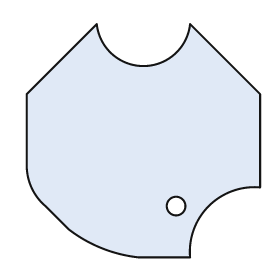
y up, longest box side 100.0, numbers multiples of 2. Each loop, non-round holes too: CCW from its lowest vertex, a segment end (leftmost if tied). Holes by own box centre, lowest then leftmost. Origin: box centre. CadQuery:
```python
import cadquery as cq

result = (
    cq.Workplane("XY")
    .moveTo(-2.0, -50.0)
    .lineTo(20.0, -50.0)
    .threePointArc((28.0, -28.0), (50.0, -20.0))
    .lineTo(50.0, 20.0)
    .lineTo(20.0, 50.0)
    .threePointArc((0.0, 32.0), (-20.0, 50.0))
    .lineTo(-50.0, 20.0)
    .lineTo(-50.0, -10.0)
    .threePointArc((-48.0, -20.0), (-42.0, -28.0))
    .lineTo(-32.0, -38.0)
    .threePointArc((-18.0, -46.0), (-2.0, -50.0))
    .close()
    .moveTo(14.0, -28.0)
    .circle(4.0)
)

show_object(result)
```